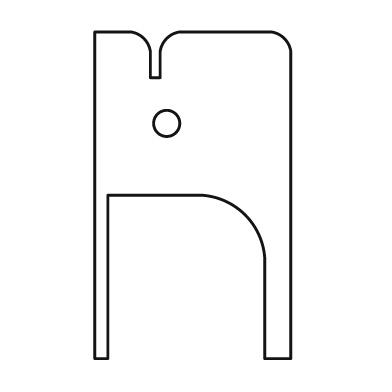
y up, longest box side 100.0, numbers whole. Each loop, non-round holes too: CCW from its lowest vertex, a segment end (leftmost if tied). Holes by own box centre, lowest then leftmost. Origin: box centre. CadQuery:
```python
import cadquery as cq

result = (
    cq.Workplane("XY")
    .moveTo(-30.0, -50.0)
    .lineTo(-26.0, -50.0)
    .lineTo(-26.0, 0.0)
    .lineTo(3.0, 0.0)
    .threePointArc((16.0, -6.0), (22.0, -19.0))
    .lineTo(22.0, -50.0)
    .lineTo(30.0, -50.0)
    .lineTo(30.0, 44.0)
    .threePointArc((28.0, 48.0), (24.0, 50.0))
    .lineTo(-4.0, 50.0)
    .threePointArc((-8.0, 48.0), (-10.0, 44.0))
    .lineTo(-10.0, 36.0)
    .lineTo(-13.0, 36.0)
    .lineTo(-13.0, 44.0)
    .threePointArc((-15.0, 48.0), (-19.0, 50.0))
    .lineTo(-30.0, 50.0)
    .close()
    .moveTo(-8.0, 22.0)
    .circle(4.0)
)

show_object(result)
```